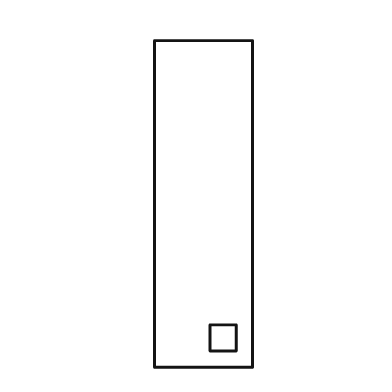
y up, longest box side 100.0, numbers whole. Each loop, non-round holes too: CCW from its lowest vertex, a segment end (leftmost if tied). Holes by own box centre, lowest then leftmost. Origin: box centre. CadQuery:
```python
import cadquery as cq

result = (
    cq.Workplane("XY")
    .moveTo(-15.0, -50.0)
    .lineTo(15.0, -50.0)
    .lineTo(15.0, 50.0)
    .lineTo(-15.0, 50.0)
    .close()
    .moveTo(2.0, -45.0)
    .lineTo(10.0, -45.0)
    .lineTo(10.0, -37.0)
    .lineTo(2.0, -37.0)
    .close()
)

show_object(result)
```